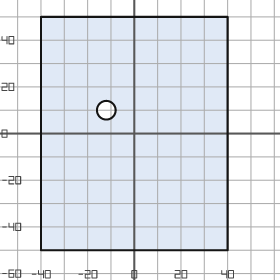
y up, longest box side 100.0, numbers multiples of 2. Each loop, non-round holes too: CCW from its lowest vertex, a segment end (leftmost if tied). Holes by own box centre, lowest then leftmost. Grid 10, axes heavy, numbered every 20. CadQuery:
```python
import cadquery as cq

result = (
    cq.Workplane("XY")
    .moveTo(-40.0, -50.0)
    .lineTo(40.0, -50.0)
    .lineTo(40.0, 50.0)
    .lineTo(-40.0, 50.0)
    .close()
    .moveTo(-12.0, 10.0)
    .circle(4.0)
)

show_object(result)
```